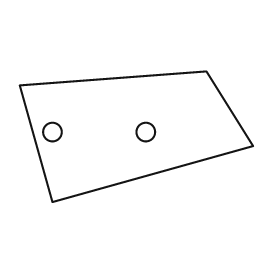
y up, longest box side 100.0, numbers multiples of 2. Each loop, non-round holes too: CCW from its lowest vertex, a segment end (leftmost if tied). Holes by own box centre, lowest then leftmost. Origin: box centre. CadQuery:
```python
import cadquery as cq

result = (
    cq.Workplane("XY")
    .moveTo(-36.0, -28.0)
    .lineTo(50.0, -4.0)
    .lineTo(30.0, 28.0)
    .lineTo(-50.0, 22.0)
    .close()
    .moveTo(-36.0, 2.0)
    .circle(4.0)
    .moveTo(4.0, 2.0)
    .circle(4.0)
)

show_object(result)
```